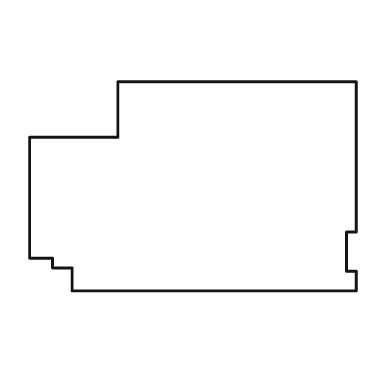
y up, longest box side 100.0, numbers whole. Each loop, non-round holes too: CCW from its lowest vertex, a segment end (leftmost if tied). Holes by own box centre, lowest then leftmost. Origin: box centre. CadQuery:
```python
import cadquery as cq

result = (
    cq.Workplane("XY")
    .moveTo(-37.0, -32.0)
    .lineTo(50.0, -32.0)
    .lineTo(50.0, -26.0)
    .lineTo(47.0, -26.0)
    .lineTo(47.0, -14.0)
    .lineTo(50.0, -14.0)
    .lineTo(50.0, 32.0)
    .lineTo(-23.0, 32.0)
    .lineTo(-23.0, 15.0)
    .lineTo(-50.0, 15.0)
    .lineTo(-50.0, -22.0)
    .lineTo(-43.0, -22.0)
    .lineTo(-43.0, -25.0)
    .lineTo(-37.0, -25.0)
    .close()
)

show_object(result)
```